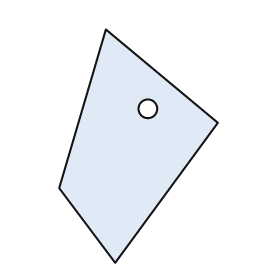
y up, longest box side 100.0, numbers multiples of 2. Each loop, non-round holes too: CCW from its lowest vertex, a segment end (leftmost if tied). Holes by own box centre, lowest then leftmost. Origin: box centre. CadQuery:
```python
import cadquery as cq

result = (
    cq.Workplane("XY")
    .moveTo(-10.0, -50.0)
    .lineTo(34.0, 10.0)
    .lineTo(-14.0, 50.0)
    .lineTo(-34.0, -18.0)
    .close()
    .moveTo(4.0, 16.0)
    .circle(4.0)
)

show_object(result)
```